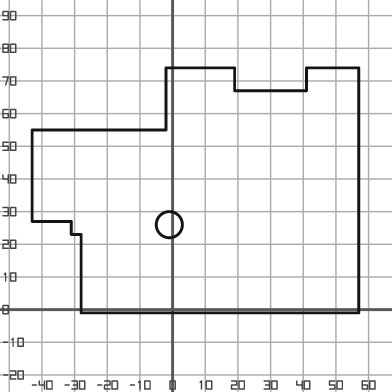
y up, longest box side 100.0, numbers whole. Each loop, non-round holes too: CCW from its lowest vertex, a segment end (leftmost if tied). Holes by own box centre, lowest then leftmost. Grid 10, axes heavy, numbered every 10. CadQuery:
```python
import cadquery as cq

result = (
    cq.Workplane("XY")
    .moveTo(-28.0, -1.0)
    .lineTo(57.0, -1.0)
    .lineTo(57.0, 74.0)
    .lineTo(41.0, 74.0)
    .lineTo(41.0, 67.0)
    .lineTo(19.0, 67.0)
    .lineTo(19.0, 74.0)
    .lineTo(-2.0, 74.0)
    .lineTo(-2.0, 55.0)
    .lineTo(-43.0, 55.0)
    .lineTo(-43.0, 27.0)
    .lineTo(-31.0, 27.0)
    .lineTo(-31.0, 23.0)
    .lineTo(-28.0, 23.0)
    .close()
    .moveTo(-1.0, 26.0)
    .circle(4.0)
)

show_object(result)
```